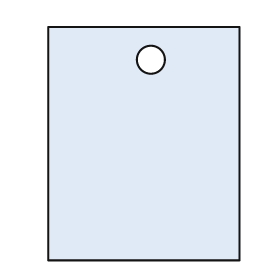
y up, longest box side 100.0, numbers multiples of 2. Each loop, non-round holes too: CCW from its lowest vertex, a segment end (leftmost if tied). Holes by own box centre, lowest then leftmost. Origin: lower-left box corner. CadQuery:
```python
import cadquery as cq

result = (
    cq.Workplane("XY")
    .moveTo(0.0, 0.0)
    .lineTo(82.0, 0.0)
    .lineTo(82.0, 100.0)
    .lineTo(0.0, 100.0)
    .close()
    .moveTo(44.0, 86.0)
    .circle(6.0)
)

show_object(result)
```